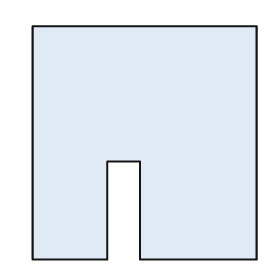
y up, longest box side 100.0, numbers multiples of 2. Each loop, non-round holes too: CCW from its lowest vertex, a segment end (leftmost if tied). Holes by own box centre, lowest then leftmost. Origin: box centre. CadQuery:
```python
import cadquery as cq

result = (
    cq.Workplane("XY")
    .moveTo(-48.0, -50.0)
    .lineTo(-16.0, -50.0)
    .lineTo(-16.0, -8.0)
    .lineTo(-2.0, -8.0)
    .lineTo(-2.0, -50.0)
    .lineTo(48.0, -50.0)
    .lineTo(48.0, 50.0)
    .lineTo(-48.0, 50.0)
    .close()
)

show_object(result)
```